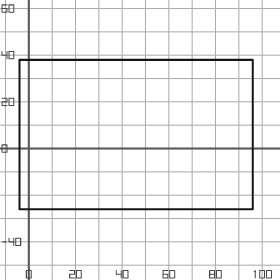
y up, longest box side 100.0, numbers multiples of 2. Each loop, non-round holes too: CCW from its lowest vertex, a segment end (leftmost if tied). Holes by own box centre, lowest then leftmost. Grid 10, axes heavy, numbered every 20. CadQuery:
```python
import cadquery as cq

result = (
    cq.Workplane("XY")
    .moveTo(-4.0, -26.0)
    .lineTo(96.0, -26.0)
    .lineTo(96.0, 38.0)
    .lineTo(-4.0, 38.0)
    .close()
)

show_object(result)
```